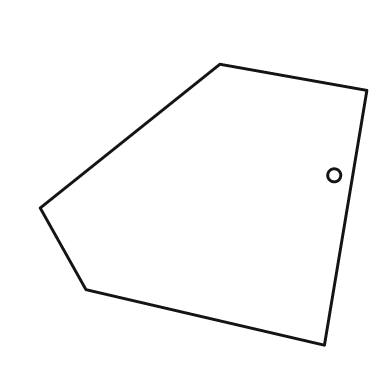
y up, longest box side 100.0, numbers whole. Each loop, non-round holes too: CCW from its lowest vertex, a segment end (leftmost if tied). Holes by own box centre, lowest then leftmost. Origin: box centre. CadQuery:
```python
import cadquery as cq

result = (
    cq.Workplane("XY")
    .moveTo(37.0, -43.0)
    .lineTo(50.0, 35.0)
    .lineTo(5.0, 43.0)
    .lineTo(-50.0, -1.0)
    .lineTo(-36.0, -26.0)
    .close()
    .moveTo(40.0, 9.0)
    .circle(2.0)
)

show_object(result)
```